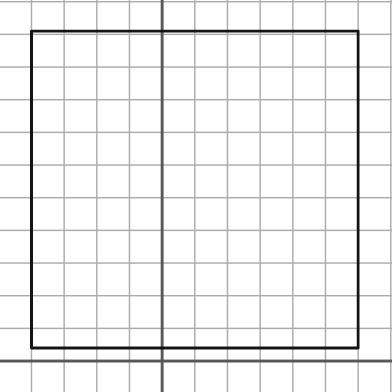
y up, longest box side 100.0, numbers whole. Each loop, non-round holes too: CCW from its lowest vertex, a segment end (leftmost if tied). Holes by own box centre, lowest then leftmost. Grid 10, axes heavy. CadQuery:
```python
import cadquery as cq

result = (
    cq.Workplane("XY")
    .moveTo(-40.0, 4.0)
    .lineTo(60.0, 4.0)
    .lineTo(60.0, 101.0)
    .lineTo(-40.0, 101.0)
    .close()
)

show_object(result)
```